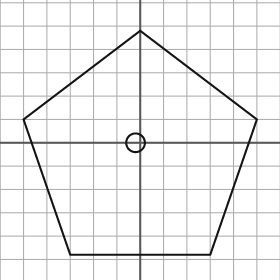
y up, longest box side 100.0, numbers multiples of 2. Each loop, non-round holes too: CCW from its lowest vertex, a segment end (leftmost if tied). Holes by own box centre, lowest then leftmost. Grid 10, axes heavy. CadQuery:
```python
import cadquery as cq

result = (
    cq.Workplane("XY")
    .moveTo(-30.0, -48.0)
    .lineTo(30.0, -48.0)
    .lineTo(50.0, 10.0)
    .lineTo(0.0, 48.0)
    .lineTo(-50.0, 10.0)
    .close()
    .moveTo(-2.0, 0.0)
    .circle(4.0)
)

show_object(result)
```